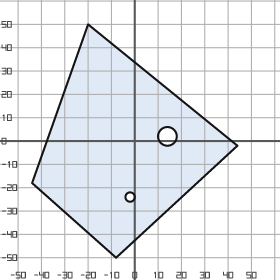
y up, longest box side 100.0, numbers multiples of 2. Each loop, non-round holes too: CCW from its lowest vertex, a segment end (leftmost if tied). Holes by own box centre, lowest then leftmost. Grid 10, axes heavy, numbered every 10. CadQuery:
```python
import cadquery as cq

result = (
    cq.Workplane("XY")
    .moveTo(-8.0, -50.0)
    .lineTo(44.0, -2.0)
    .lineTo(-20.0, 50.0)
    .lineTo(-44.0, -18.0)
    .close()
    .moveTo(-2.0, -24.0)
    .circle(2.0)
    .moveTo(14.0, 2.0)
    .circle(4.0)
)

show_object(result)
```